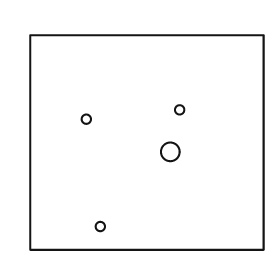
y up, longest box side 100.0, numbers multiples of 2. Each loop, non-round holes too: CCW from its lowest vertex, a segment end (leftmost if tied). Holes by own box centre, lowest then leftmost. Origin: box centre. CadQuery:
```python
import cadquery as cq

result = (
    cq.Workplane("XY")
    .moveTo(-50.0, -46.0)
    .lineTo(50.0, -46.0)
    .lineTo(50.0, 46.0)
    .lineTo(-50.0, 46.0)
    .close()
    .moveTo(-20.0, -36.0)
    .circle(2.0)
    .moveTo(10.0, -4.0)
    .circle(4.0)
    .moveTo(-26.0, 10.0)
    .circle(2.0)
    .moveTo(14.0, 14.0)
    .circle(2.0)
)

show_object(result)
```